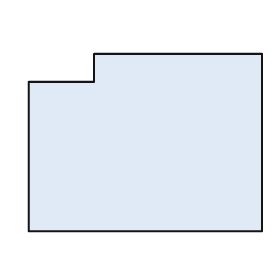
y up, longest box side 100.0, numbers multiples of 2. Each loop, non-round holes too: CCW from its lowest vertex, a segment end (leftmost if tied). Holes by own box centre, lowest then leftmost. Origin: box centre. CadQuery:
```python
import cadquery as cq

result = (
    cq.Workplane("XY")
    .moveTo(-50.0, -38.0)
    .lineTo(50.0, -38.0)
    .lineTo(50.0, 38.0)
    .lineTo(-22.0, 38.0)
    .lineTo(-22.0, 26.0)
    .lineTo(-50.0, 26.0)
    .close()
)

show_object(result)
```